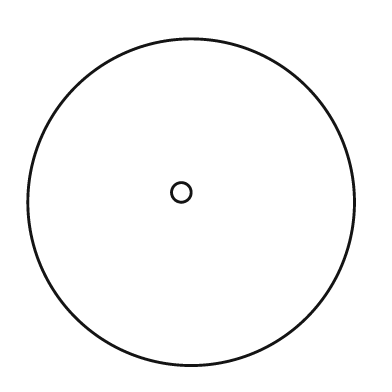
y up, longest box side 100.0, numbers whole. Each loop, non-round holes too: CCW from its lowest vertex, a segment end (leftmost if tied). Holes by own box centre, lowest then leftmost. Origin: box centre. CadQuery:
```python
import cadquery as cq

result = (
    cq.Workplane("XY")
    .moveTo(0.0, 0.0)
    .circle(50.0)
    .moveTo(-3.0, 3.0)
    .circle(3.0)
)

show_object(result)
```